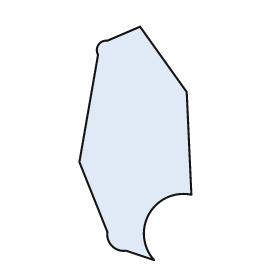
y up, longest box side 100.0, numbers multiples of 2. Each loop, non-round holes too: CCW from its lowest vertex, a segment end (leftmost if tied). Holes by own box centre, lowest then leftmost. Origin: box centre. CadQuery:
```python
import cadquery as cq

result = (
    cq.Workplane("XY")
    .moveTo(8.0, -50.0)
    .threePointArc((6.0, -30.0), (24.0, -22.0))
    .lineTo(22.0, 22.0)
    .lineTo(2.0, 50.0)
    .lineTo(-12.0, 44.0)
    .threePointArc((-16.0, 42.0), (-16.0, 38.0))
    .lineTo(-24.0, -8.0)
    .lineTo(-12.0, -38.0)
    .threePointArc((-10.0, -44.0), (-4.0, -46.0))
    .close()
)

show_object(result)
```